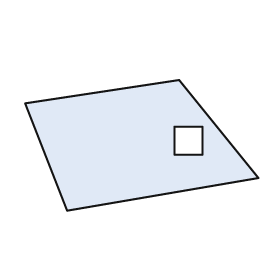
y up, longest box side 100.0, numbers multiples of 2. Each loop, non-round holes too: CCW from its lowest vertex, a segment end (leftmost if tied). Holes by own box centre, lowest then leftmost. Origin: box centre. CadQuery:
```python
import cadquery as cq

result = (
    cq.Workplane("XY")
    .moveTo(-32.0, -28.0)
    .lineTo(50.0, -14.0)
    .lineTo(16.0, 28.0)
    .lineTo(-50.0, 18.0)
    .close()
    .moveTo(14.0, -4.0)
    .lineTo(26.0, -4.0)
    .lineTo(26.0, 8.0)
    .lineTo(14.0, 8.0)
    .close()
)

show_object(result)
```